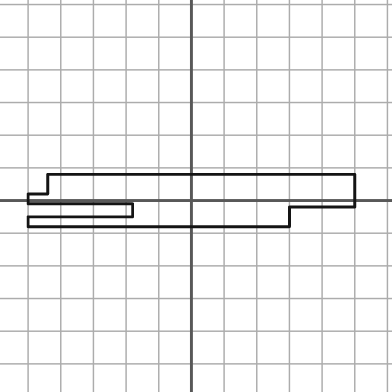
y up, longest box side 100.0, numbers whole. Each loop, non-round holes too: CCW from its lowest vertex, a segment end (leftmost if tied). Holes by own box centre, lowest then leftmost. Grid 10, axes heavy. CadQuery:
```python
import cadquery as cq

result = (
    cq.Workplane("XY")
    .moveTo(-50.0, -8.0)
    .lineTo(30.0, -8.0)
    .lineTo(30.0, -2.0)
    .lineTo(50.0, -2.0)
    .lineTo(50.0, 8.0)
    .lineTo(-44.0, 8.0)
    .lineTo(-44.0, 2.0)
    .lineTo(-50.0, 2.0)
    .lineTo(-50.0, -1.0)
    .lineTo(-18.0, -1.0)
    .lineTo(-18.0, -5.0)
    .lineTo(-50.0, -5.0)
    .close()
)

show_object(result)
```